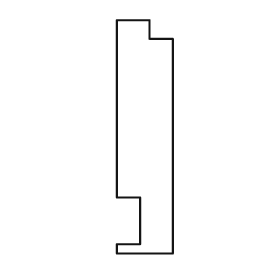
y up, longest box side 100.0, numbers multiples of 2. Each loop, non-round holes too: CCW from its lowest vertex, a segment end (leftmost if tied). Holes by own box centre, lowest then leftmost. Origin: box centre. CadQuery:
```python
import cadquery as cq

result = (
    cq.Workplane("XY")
    .moveTo(-12.0, -50.0)
    .lineTo(12.0, -50.0)
    .lineTo(12.0, 42.0)
    .lineTo(2.0, 42.0)
    .lineTo(2.0, 50.0)
    .lineTo(-12.0, 50.0)
    .lineTo(-12.0, -26.0)
    .lineTo(-2.0, -26.0)
    .lineTo(-2.0, -46.0)
    .lineTo(-12.0, -46.0)
    .close()
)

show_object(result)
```